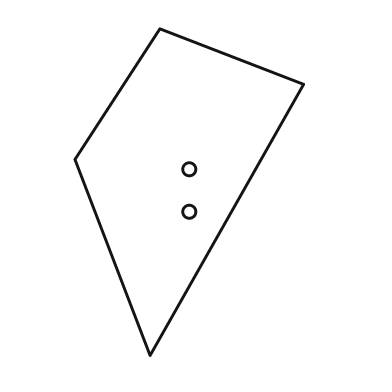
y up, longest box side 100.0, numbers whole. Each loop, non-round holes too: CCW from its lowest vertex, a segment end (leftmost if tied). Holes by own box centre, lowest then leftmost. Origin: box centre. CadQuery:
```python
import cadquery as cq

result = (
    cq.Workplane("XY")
    .moveTo(-12.0, -50.0)
    .lineTo(35.0, 33.0)
    .lineTo(-9.0, 50.0)
    .lineTo(-35.0, 10.0)
    .close()
    .moveTo(0.0, -6.0)
    .circle(2.0)
    .moveTo(0.0, 7.0)
    .circle(2.0)
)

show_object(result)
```